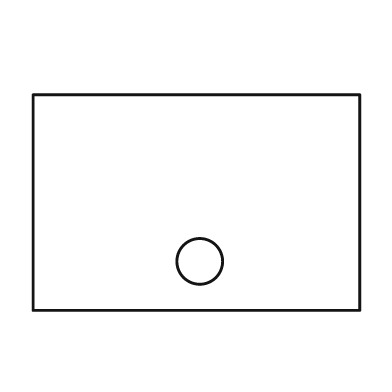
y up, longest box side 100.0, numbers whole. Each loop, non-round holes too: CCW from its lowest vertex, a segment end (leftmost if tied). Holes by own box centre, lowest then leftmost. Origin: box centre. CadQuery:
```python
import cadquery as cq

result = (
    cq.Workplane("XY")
    .moveTo(-50.0, -33.0)
    .lineTo(50.0, -33.0)
    .lineTo(50.0, 33.0)
    .lineTo(-50.0, 33.0)
    .close()
    .moveTo(1.0, -18.0)
    .circle(7.0)
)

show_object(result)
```